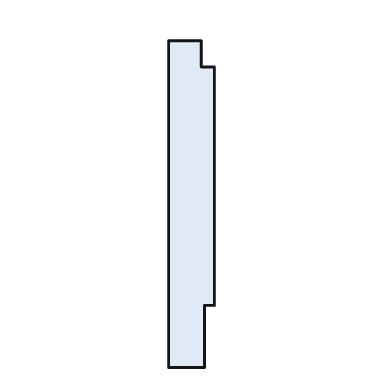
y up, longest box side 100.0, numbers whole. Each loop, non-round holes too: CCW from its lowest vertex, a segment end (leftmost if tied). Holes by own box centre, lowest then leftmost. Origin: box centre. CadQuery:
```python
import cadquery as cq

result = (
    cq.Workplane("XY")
    .moveTo(-7.0, -50.0)
    .lineTo(4.0, -50.0)
    .lineTo(4.0, -31.0)
    .lineTo(7.0, -31.0)
    .lineTo(7.0, 42.0)
    .lineTo(3.0, 42.0)
    .lineTo(3.0, 50.0)
    .lineTo(-7.0, 50.0)
    .close()
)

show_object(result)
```